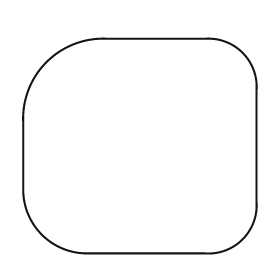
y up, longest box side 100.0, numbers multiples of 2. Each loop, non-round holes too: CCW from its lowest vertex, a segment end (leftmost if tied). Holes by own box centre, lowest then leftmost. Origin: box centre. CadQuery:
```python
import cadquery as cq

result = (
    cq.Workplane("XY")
    .moveTo(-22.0, -46.0)
    .lineTo(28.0, -46.0)
    .threePointArc((44.0, -40.0), (50.0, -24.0))
    .lineTo(50.0, 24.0)
    .threePointArc((44.0, 40.0), (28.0, 46.0))
    .lineTo(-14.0, 46.0)
    .threePointArc((-40.0, 36.0), (-50.0, 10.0))
    .lineTo(-50.0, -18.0)
    .threePointArc((-42.0, -38.0), (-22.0, -46.0))
    .close()
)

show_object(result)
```